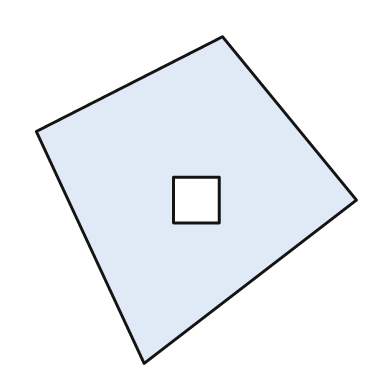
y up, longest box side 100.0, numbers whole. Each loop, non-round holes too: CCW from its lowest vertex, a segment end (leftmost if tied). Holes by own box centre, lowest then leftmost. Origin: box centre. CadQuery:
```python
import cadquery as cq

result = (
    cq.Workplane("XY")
    .moveTo(-16.0, -50.0)
    .lineTo(49.0, 0.0)
    .lineTo(8.0, 50.0)
    .lineTo(-49.0, 21.0)
    .close()
    .moveTo(-7.0, -7.0)
    .lineTo(7.0, -7.0)
    .lineTo(7.0, 7.0)
    .lineTo(-7.0, 7.0)
    .close()
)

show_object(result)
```